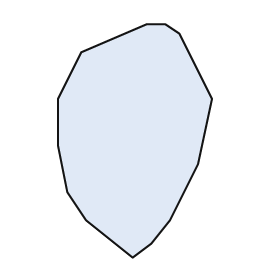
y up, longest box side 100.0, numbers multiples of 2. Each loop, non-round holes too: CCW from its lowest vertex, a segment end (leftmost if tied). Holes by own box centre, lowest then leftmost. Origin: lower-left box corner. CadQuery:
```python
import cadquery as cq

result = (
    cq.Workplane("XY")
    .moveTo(32.0, 0.0)
    .lineTo(40.0, 6.0)
    .lineTo(48.0, 16.0)
    .lineTo(60.0, 40.0)
    .lineTo(66.0, 68.0)
    .lineTo(52.0, 96.0)
    .lineTo(46.0, 100.0)
    .lineTo(38.0, 100.0)
    .lineTo(10.0, 88.0)
    .lineTo(0.0, 68.0)
    .lineTo(0.0, 48.0)
    .lineTo(4.0, 28.0)
    .lineTo(12.0, 16.0)
    .close()
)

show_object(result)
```